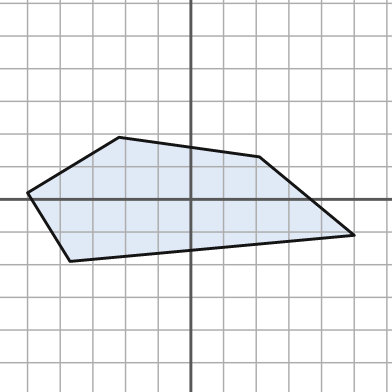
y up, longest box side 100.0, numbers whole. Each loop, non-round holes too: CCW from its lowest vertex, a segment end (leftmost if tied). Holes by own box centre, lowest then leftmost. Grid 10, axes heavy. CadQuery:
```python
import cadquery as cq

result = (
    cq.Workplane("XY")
    .moveTo(-37.0, -19.0)
    .lineTo(50.0, -11.0)
    .lineTo(21.0, 13.0)
    .lineTo(-22.0, 19.0)
    .lineTo(-50.0, 2.0)
    .close()
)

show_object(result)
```